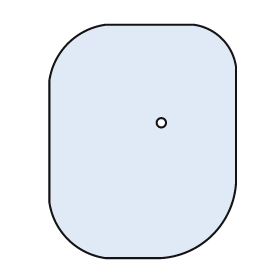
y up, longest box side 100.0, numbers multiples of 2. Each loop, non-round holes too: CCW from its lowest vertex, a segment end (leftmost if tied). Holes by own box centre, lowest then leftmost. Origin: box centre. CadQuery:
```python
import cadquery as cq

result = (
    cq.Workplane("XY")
    .moveTo(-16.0, -50.0)
    .lineTo(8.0, -50.0)
    .threePointArc((30.0, -40.0), (40.0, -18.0))
    .lineTo(40.0, 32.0)
    .threePointArc((34.0, 44.0), (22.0, 50.0))
    .lineTo(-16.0, 50.0)
    .threePointArc((-32.0, 42.0), (-40.0, 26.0))
    .lineTo(-40.0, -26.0)
    .threePointArc((-32.0, -42.0), (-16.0, -50.0))
    .close()
    .moveTo(8.0, 8.0)
    .circle(2.0)
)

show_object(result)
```